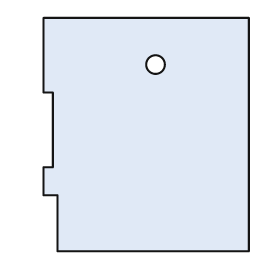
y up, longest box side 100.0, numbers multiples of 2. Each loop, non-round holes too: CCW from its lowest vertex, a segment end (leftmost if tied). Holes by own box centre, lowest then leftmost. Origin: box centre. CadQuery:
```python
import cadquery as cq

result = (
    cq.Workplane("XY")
    .moveTo(-38.0, -50.0)
    .lineTo(44.0, -50.0)
    .lineTo(44.0, 50.0)
    .lineTo(-44.0, 50.0)
    .lineTo(-44.0, 18.0)
    .lineTo(-40.0, 18.0)
    .lineTo(-40.0, -14.0)
    .lineTo(-44.0, -14.0)
    .lineTo(-44.0, -26.0)
    .lineTo(-38.0, -26.0)
    .close()
    .moveTo(4.0, 30.0)
    .circle(4.0)
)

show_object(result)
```